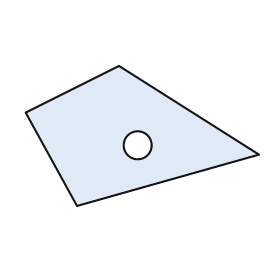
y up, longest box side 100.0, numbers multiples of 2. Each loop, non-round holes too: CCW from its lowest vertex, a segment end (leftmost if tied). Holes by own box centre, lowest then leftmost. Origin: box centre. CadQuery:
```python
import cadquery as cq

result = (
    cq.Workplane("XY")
    .moveTo(-28.0, -30.0)
    .lineTo(50.0, -8.0)
    .lineTo(-10.0, 30.0)
    .lineTo(-50.0, 10.0)
    .close()
    .moveTo(-2.0, -4.0)
    .circle(6.0)
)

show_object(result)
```